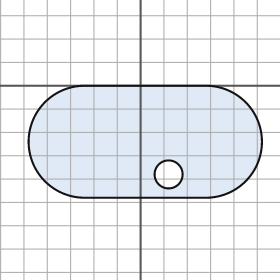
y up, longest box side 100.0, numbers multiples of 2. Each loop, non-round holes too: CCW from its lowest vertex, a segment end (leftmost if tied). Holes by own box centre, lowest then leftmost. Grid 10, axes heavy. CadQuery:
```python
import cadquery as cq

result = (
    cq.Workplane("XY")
    .moveTo(-24.0, -48.0)
    .lineTo(28.0, -48.0)
    .threePointArc((52.0, -24.0), (28.0, 0.0))
    .lineTo(-24.0, 0.0)
    .threePointArc((-48.0, -24.0), (-24.0, -48.0))
    .close()
    .moveTo(12.0, -38.0)
    .circle(6.0)
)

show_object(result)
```